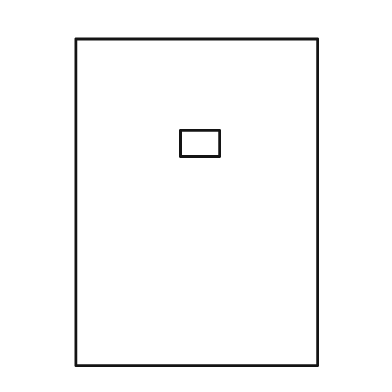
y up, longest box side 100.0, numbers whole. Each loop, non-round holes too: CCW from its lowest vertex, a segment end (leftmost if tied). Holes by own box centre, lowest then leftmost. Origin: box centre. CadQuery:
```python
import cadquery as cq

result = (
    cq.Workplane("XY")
    .moveTo(-37.0, -50.0)
    .lineTo(37.0, -50.0)
    .lineTo(37.0, 50.0)
    .lineTo(-37.0, 50.0)
    .close()
    .moveTo(-5.0, 14.0)
    .lineTo(7.0, 14.0)
    .lineTo(7.0, 22.0)
    .lineTo(-5.0, 22.0)
    .close()
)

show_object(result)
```